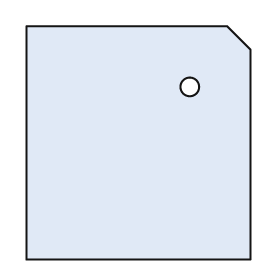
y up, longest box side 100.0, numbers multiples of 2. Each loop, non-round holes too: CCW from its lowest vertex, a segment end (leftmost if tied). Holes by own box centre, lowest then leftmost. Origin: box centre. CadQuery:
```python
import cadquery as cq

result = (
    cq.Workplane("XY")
    .moveTo(-48.0, -50.0)
    .lineTo(48.0, -50.0)
    .lineTo(48.0, 40.0)
    .lineTo(38.0, 50.0)
    .lineTo(-48.0, 50.0)
    .close()
    .moveTo(22.0, 24.0)
    .circle(4.0)
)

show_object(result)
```